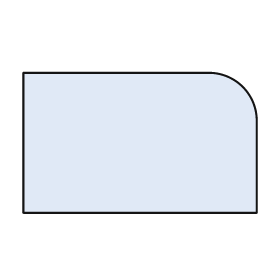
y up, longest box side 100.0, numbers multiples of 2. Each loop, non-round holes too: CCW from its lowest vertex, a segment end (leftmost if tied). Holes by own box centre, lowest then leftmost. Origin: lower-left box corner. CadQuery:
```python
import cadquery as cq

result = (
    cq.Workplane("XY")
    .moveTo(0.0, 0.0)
    .lineTo(100.0, 0.0)
    .lineTo(100.0, 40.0)
    .threePointArc((94.0, 54.0), (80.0, 60.0))
    .lineTo(0.0, 60.0)
    .close()
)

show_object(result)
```